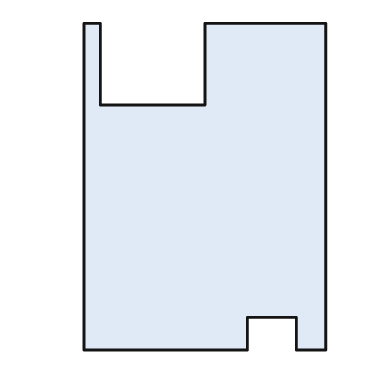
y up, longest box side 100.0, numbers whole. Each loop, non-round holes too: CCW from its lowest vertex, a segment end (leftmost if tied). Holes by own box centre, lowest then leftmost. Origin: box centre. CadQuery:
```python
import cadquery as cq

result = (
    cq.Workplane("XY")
    .moveTo(-37.0, -50.0)
    .lineTo(13.0, -50.0)
    .lineTo(13.0, -40.0)
    .lineTo(28.0, -40.0)
    .lineTo(28.0, -50.0)
    .lineTo(37.0, -50.0)
    .lineTo(37.0, 50.0)
    .lineTo(0.0, 50.0)
    .lineTo(0.0, 25.0)
    .lineTo(-32.0, 25.0)
    .lineTo(-32.0, 50.0)
    .lineTo(-37.0, 50.0)
    .close()
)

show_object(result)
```